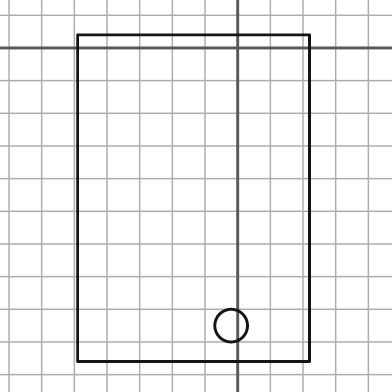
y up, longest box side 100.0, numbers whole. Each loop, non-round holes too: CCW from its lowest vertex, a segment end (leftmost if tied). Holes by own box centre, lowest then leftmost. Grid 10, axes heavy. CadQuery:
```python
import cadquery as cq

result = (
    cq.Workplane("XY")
    .moveTo(-49.0, -96.0)
    .lineTo(22.0, -96.0)
    .lineTo(22.0, 4.0)
    .lineTo(-49.0, 4.0)
    .close()
    .moveTo(-2.0, -85.0)
    .circle(5.0)
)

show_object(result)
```